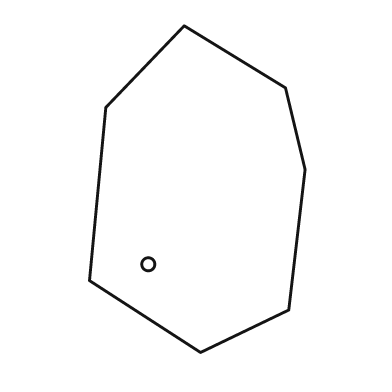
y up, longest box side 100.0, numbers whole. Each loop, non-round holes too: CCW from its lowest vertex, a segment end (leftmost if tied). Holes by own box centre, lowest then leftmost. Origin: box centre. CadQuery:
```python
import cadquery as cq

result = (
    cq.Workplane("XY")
    .moveTo(1.0, -50.0)
    .lineTo(28.0, -37.0)
    .lineTo(33.0, 6.0)
    .lineTo(27.0, 31.0)
    .lineTo(-4.0, 50.0)
    .lineTo(-28.0, 25.0)
    .lineTo(-33.0, -28.0)
    .close()
    .moveTo(-15.0, -23.0)
    .circle(2.0)
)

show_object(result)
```